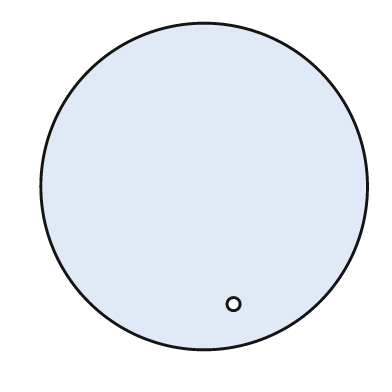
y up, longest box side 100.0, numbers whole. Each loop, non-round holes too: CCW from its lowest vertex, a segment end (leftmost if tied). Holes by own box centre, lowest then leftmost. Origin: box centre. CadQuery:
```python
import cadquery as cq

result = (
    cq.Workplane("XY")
    .moveTo(0.0, 0.0)
    .circle(50.0)
    .moveTo(9.0, -36.0)
    .circle(2.0)
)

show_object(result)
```